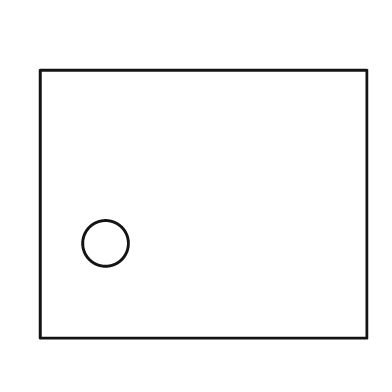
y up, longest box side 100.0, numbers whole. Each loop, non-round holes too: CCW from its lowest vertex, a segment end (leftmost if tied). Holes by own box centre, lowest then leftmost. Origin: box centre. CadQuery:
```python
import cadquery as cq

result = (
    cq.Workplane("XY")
    .moveTo(-50.0, -41.0)
    .lineTo(50.0, -41.0)
    .lineTo(50.0, 41.0)
    .lineTo(-50.0, 41.0)
    .close()
    .moveTo(-30.0, -12.0)
    .circle(7.0)
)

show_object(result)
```